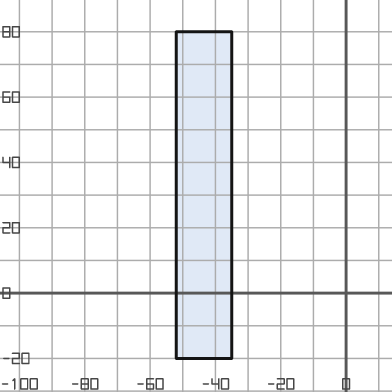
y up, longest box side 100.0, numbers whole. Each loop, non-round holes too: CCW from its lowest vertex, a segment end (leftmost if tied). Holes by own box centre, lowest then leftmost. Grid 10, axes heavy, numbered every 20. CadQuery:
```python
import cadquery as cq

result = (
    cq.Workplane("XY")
    .moveTo(-52.0, -20.0)
    .lineTo(-35.0, -20.0)
    .lineTo(-35.0, 80.0)
    .lineTo(-52.0, 80.0)
    .close()
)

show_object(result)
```